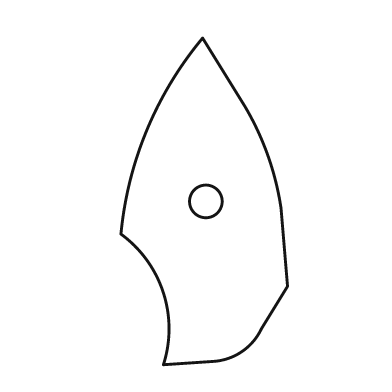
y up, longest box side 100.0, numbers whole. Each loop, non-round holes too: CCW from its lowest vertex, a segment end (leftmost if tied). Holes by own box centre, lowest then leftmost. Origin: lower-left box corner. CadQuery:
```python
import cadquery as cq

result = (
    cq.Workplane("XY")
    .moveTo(13.0, 0.0)
    .lineTo(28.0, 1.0)
    .threePointArc((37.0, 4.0), (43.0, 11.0))
    .lineTo(51.0, 24.0)
    .lineTo(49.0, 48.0)
    .threePointArc((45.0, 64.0), (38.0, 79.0))
    .lineTo(25.0, 100.0)
    .threePointArc((8.0, 72.0), (0.0, 40.0))
    .threePointArc((13.0, 22.0), (13.0, 0.0))
    .close()
    .moveTo(26.0, 50.0)
    .circle(5.0)
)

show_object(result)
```